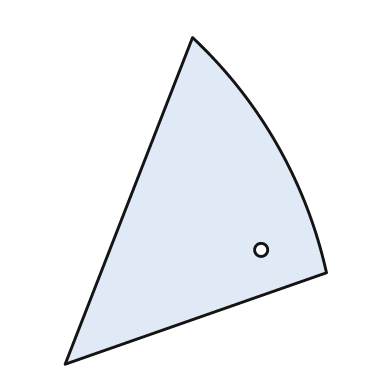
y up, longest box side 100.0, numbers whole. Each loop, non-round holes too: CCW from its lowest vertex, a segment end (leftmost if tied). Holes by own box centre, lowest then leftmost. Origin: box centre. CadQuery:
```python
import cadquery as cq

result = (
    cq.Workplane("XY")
    .moveTo(-40.0, -50.0)
    .lineTo(40.0, -22.0)
    .threePointArc((25.0, 17.0), (-1.0, 50.0))
    .close()
    .moveTo(20.0, -15.0)
    .circle(2.0)
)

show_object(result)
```